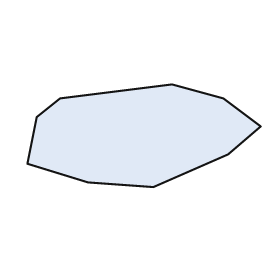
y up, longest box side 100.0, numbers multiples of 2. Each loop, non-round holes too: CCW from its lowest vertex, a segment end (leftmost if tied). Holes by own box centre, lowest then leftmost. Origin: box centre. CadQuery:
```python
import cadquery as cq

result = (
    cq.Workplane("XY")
    .moveTo(4.0, -22.0)
    .lineTo(36.0, -8.0)
    .lineTo(50.0, 4.0)
    .lineTo(34.0, 16.0)
    .lineTo(12.0, 22.0)
    .lineTo(-36.0, 16.0)
    .lineTo(-46.0, 8.0)
    .lineTo(-50.0, -12.0)
    .lineTo(-24.0, -20.0)
    .close()
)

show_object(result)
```